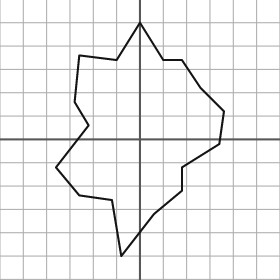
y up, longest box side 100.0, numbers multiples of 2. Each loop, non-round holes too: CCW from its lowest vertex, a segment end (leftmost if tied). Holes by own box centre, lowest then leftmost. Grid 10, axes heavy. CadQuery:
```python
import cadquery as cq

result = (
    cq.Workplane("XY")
    .moveTo(-8.0, -50.0)
    .lineTo(6.0, -32.0)
    .lineTo(18.0, -22.0)
    .lineTo(18.0, -12.0)
    .lineTo(34.0, -2.0)
    .lineTo(36.0, 12.0)
    .lineTo(26.0, 22.0)
    .lineTo(18.0, 34.0)
    .lineTo(10.0, 34.0)
    .lineTo(0.0, 50.0)
    .lineTo(-10.0, 34.0)
    .lineTo(-26.0, 36.0)
    .lineTo(-28.0, 16.0)
    .lineTo(-22.0, 6.0)
    .lineTo(-36.0, -12.0)
    .lineTo(-26.0, -24.0)
    .lineTo(-12.0, -26.0)
    .close()
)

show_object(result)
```